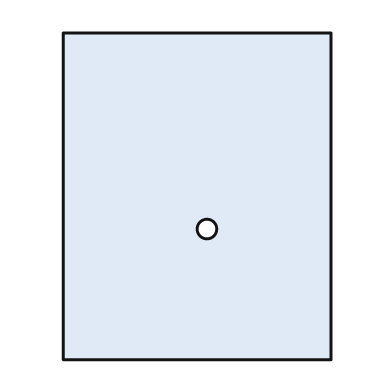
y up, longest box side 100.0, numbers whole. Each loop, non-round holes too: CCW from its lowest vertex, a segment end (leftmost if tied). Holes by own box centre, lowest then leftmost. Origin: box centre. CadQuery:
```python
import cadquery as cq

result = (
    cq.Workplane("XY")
    .moveTo(-41.0, -50.0)
    .lineTo(41.0, -50.0)
    .lineTo(41.0, 50.0)
    .lineTo(-41.0, 50.0)
    .close()
    .moveTo(3.0, -10.0)
    .circle(3.0)
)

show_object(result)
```